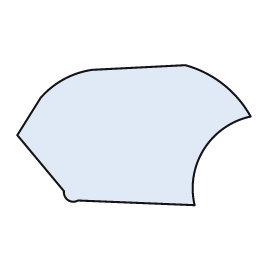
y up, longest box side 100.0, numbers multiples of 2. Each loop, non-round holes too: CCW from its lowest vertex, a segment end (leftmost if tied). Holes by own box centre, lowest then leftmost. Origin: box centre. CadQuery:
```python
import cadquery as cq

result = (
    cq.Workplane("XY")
    .moveTo(26.0, -30.0)
    .threePointArc((30.0, -6.0), (50.0, 8.0))
    .threePointArc((38.0, 22.0), (22.0, 30.0))
    .lineTo(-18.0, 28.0)
    .threePointArc((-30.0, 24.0), (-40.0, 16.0))
    .lineTo(-50.0, 0.0)
    .lineTo(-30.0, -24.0)
    .threePointArc((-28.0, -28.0), (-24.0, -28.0))
    .close()
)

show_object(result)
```